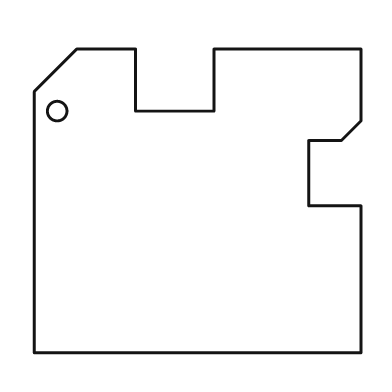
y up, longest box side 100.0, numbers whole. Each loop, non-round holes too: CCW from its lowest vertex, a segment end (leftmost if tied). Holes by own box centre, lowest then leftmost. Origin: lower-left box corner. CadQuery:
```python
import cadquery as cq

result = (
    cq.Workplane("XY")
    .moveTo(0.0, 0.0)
    .lineTo(100.0, 0.0)
    .lineTo(100.0, 45.0)
    .lineTo(84.0, 45.0)
    .lineTo(84.0, 65.0)
    .lineTo(94.0, 65.0)
    .lineTo(100.0, 71.0)
    .lineTo(100.0, 93.0)
    .lineTo(55.0, 93.0)
    .lineTo(55.0, 74.0)
    .lineTo(31.0, 74.0)
    .lineTo(31.0, 93.0)
    .lineTo(13.0, 93.0)
    .lineTo(0.0, 80.0)
    .close()
    .moveTo(7.0, 74.0)
    .circle(3.0)
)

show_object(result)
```